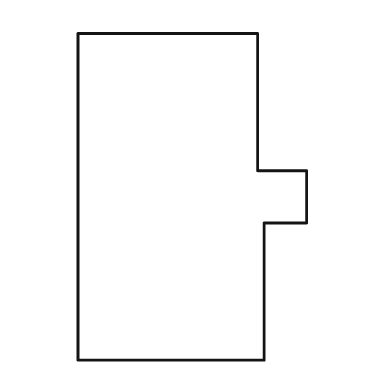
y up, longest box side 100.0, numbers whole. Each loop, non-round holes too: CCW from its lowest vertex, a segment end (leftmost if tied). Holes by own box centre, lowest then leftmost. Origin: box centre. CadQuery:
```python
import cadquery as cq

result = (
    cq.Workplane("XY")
    .moveTo(-35.0, -50.0)
    .lineTo(22.0, -50.0)
    .lineTo(22.0, -8.0)
    .lineTo(35.0, -8.0)
    .lineTo(35.0, 8.0)
    .lineTo(20.0, 8.0)
    .lineTo(20.0, 50.0)
    .lineTo(-35.0, 50.0)
    .close()
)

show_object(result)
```